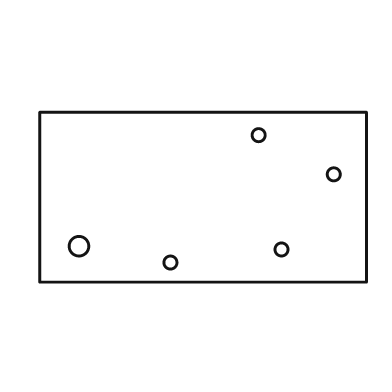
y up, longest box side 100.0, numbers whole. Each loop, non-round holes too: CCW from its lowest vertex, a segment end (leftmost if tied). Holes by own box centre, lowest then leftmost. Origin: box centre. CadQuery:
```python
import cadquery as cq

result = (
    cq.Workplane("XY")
    .moveTo(-50.0, -26.0)
    .lineTo(50.0, -26.0)
    .lineTo(50.0, 26.0)
    .lineTo(-50.0, 26.0)
    .close()
    .moveTo(-10.0, -20.0)
    .circle(2.0)
    .moveTo(24.0, -16.0)
    .circle(2.0)
    .moveTo(-38.0, -15.0)
    .circle(3.0)
    .moveTo(40.0, 7.0)
    .circle(2.0)
    .moveTo(17.0, 19.0)
    .circle(2.0)
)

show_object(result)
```